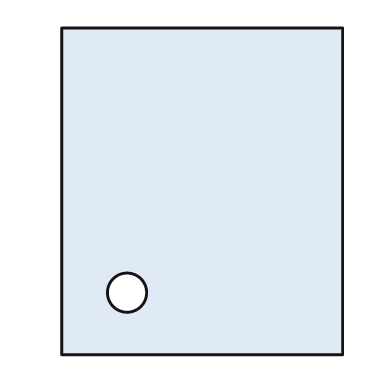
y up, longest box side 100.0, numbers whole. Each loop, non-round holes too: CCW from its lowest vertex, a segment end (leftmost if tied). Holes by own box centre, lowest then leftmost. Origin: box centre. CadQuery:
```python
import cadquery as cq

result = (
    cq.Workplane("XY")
    .moveTo(-43.0, -50.0)
    .lineTo(43.0, -50.0)
    .lineTo(43.0, 50.0)
    .lineTo(-43.0, 50.0)
    .close()
    .moveTo(-23.0, -31.0)
    .circle(6.0)
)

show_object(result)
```